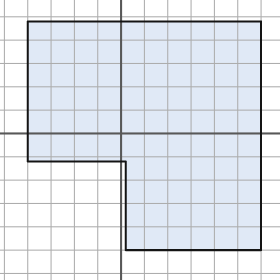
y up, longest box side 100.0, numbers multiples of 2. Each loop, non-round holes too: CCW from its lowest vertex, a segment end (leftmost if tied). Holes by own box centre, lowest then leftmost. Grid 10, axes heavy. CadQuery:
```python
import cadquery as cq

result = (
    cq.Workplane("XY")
    .moveTo(2.0, -50.0)
    .lineTo(60.0, -50.0)
    .lineTo(60.0, 48.0)
    .lineTo(-40.0, 48.0)
    .lineTo(-40.0, -12.0)
    .lineTo(2.0, -12.0)
    .close()
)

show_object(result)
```